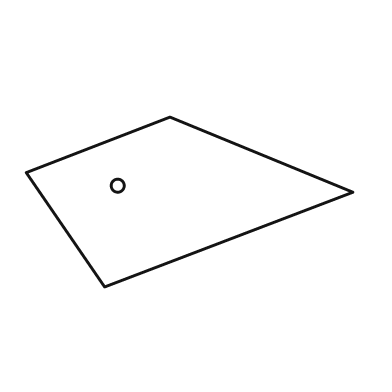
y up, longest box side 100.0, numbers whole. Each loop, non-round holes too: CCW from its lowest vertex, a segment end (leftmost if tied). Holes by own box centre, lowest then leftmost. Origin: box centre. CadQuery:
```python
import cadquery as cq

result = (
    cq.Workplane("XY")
    .moveTo(-26.0, -26.0)
    .lineTo(50.0, 3.0)
    .lineTo(-6.0, 26.0)
    .lineTo(-50.0, 9.0)
    .close()
    .moveTo(-22.0, 5.0)
    .circle(2.0)
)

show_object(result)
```